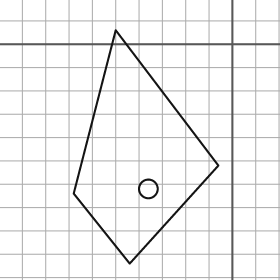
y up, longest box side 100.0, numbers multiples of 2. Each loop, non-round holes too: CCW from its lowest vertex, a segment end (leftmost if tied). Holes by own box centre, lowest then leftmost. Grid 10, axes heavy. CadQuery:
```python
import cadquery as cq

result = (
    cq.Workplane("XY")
    .moveTo(-44.0, -94.0)
    .lineTo(-6.0, -52.0)
    .lineTo(-50.0, 6.0)
    .lineTo(-68.0, -64.0)
    .close()
    .moveTo(-36.0, -62.0)
    .circle(4.0)
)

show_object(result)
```